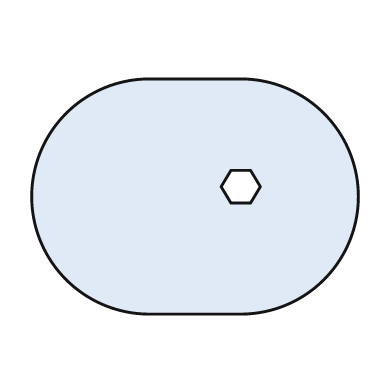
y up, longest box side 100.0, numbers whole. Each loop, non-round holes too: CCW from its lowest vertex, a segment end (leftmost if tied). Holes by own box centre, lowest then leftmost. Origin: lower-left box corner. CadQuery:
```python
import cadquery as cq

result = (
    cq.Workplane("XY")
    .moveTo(36.0, 0.0)
    .lineTo(64.0, 0.0)
    .threePointArc((100.0, 36.0), (64.0, 72.0))
    .lineTo(36.0, 72.0)
    .threePointArc((0.0, 36.0), (36.0, 0.0))
    .close()
    .moveTo(61.0, 34.0)
    .lineTo(67.0, 34.0)
    .lineTo(70.0, 39.0)
    .lineTo(67.0, 44.0)
    .lineTo(61.0, 44.0)
    .lineTo(58.0, 39.0)
    .close()
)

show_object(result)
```